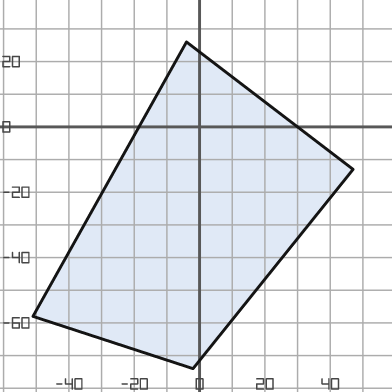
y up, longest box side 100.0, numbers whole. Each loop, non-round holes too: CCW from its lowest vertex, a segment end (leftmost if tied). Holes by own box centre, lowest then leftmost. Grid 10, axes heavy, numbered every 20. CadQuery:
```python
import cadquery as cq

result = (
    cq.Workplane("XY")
    .moveTo(-2.0, -74.0)
    .lineTo(47.0, -13.0)
    .lineTo(-4.0, 26.0)
    .lineTo(-51.0, -58.0)
    .close()
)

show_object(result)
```